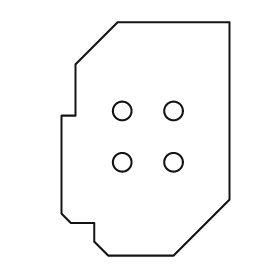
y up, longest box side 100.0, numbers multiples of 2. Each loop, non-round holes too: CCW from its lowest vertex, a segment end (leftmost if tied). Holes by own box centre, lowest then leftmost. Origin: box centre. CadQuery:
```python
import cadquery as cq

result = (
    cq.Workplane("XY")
    .moveTo(-16.0, -50.0)
    .lineTo(12.0, -50.0)
    .lineTo(36.0, -26.0)
    .lineTo(36.0, 50.0)
    .lineTo(-12.0, 50.0)
    .lineTo(-30.0, 32.0)
    .lineTo(-30.0, 10.0)
    .lineTo(-36.0, 10.0)
    .lineTo(-36.0, -32.0)
    .lineTo(-32.0, -36.0)
    .lineTo(-22.0, -36.0)
    .lineTo(-22.0, -44.0)
    .close()
    .moveTo(-10.0, -10.0)
    .circle(4.0)
    .moveTo(12.0, -10.0)
    .circle(4.0)
    .moveTo(-10.0, 12.0)
    .circle(4.0)
    .moveTo(12.0, 12.0)
    .circle(4.0)
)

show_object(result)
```